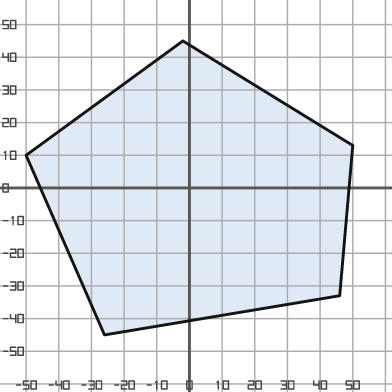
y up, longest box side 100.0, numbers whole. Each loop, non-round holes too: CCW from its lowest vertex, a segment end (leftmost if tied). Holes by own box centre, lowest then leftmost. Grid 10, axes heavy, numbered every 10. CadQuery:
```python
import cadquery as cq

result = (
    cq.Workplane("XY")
    .moveTo(-26.0, -45.0)
    .lineTo(46.0, -33.0)
    .lineTo(50.0, 13.0)
    .lineTo(-2.0, 45.0)
    .lineTo(-50.0, 10.0)
    .close()
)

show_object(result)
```